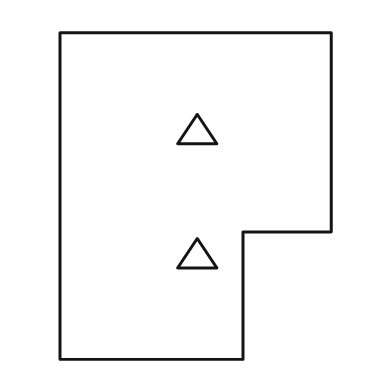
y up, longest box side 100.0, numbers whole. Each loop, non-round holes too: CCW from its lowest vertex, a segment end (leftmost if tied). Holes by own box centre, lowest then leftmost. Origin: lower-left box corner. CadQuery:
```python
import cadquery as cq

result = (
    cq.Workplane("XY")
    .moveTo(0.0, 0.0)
    .lineTo(56.0, 0.0)
    .lineTo(56.0, 39.0)
    .lineTo(83.0, 39.0)
    .lineTo(83.0, 100.0)
    .lineTo(0.0, 100.0)
    .close()
    .moveTo(36.0, 28.0)
    .lineTo(48.0, 28.0)
    .lineTo(42.0, 37.0)
    .close()
    .moveTo(36.0, 66.0)
    .lineTo(48.0, 66.0)
    .lineTo(42.0, 75.0)
    .close()
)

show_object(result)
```